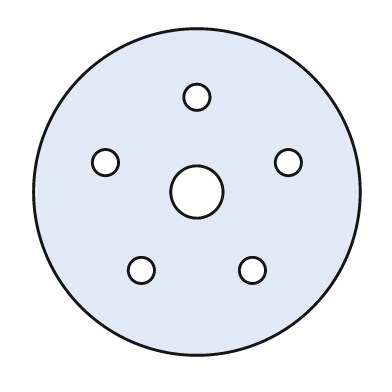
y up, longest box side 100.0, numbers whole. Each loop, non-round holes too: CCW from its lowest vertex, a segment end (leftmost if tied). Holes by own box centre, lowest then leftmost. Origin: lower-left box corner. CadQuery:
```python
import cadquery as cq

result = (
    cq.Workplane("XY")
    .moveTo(50.0, 50.0)
    .circle(50.0)
    .moveTo(33.0, 26.0)
    .circle(4.0)
    .moveTo(67.0, 26.0)
    .circle(4.0)
    .moveTo(50.0, 50.0)
    .circle(8.0)
    .moveTo(22.0, 59.0)
    .circle(4.0)
    .moveTo(78.0, 59.0)
    .circle(4.0)
    .moveTo(50.0, 79.0)
    .circle(4.0)
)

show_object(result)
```